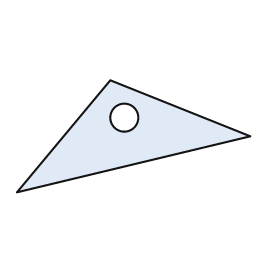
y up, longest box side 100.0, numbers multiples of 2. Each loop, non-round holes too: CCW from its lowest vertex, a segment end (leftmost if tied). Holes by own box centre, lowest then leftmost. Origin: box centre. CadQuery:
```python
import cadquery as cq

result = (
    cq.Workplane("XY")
    .moveTo(-50.0, -24.0)
    .lineTo(50.0, 0.0)
    .lineTo(-10.0, 24.0)
    .close()
    .moveTo(-4.0, 8.0)
    .circle(6.0)
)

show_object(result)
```